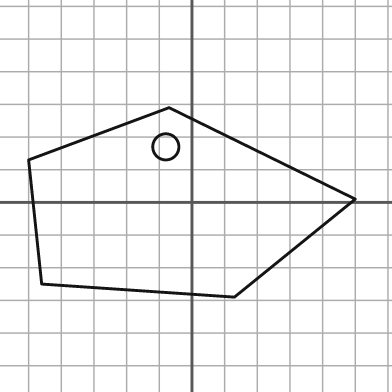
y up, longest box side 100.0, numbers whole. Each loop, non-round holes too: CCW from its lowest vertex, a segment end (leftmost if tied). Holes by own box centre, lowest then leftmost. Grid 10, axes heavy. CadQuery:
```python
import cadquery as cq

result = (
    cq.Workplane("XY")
    .moveTo(13.0, -29.0)
    .lineTo(50.0, 1.0)
    .lineTo(-7.0, 29.0)
    .lineTo(-50.0, 13.0)
    .lineTo(-46.0, -25.0)
    .close()
    .moveTo(-8.0, 17.0)
    .circle(4.0)
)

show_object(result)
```